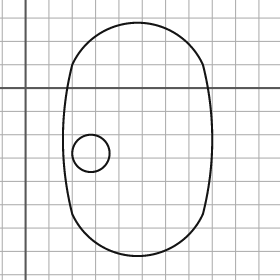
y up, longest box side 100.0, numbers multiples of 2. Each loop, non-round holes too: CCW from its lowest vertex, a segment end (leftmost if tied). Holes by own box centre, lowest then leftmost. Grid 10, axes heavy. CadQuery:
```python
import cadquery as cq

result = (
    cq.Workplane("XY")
    .moveTo(20.0, -54.0)
    .threePointArc((48.0, -72.0), (76.0, -54.0))
    .threePointArc((80.0, -22.0), (76.0, 10.0))
    .threePointArc((48.0, 28.0), (20.0, 10.0))
    .threePointArc((16.0, -22.0), (20.0, -54.0))
    .close()
    .moveTo(28.0, -28.0)
    .circle(8.0)
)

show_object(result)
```